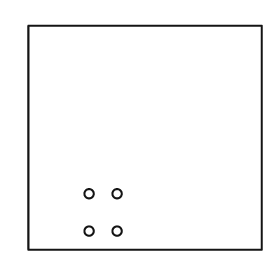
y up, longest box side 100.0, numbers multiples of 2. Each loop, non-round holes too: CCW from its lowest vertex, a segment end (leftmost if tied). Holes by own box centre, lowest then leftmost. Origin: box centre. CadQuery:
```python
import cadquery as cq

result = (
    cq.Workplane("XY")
    .moveTo(-50.0, -48.0)
    .lineTo(50.0, -48.0)
    .lineTo(50.0, 48.0)
    .lineTo(-50.0, 48.0)
    .close()
    .moveTo(-24.0, -40.0)
    .circle(2.0)
    .moveTo(-12.0, -40.0)
    .circle(2.0)
    .moveTo(-24.0, -24.0)
    .circle(2.0)
    .moveTo(-12.0, -24.0)
    .circle(2.0)
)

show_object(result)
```